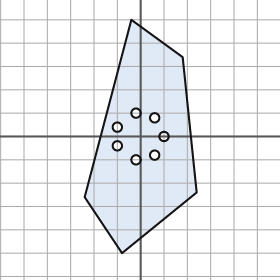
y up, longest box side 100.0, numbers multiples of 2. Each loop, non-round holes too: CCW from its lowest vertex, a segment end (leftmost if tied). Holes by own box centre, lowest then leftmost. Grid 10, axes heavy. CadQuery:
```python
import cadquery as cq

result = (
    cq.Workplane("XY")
    .moveTo(-8.0, -50.0)
    .lineTo(24.0, -24.0)
    .lineTo(18.0, 34.0)
    .lineTo(-4.0, 50.0)
    .lineTo(-24.0, -26.0)
    .close()
    .moveTo(-2.0, -10.0)
    .circle(2.0)
    .moveTo(6.0, -8.0)
    .circle(2.0)
    .moveTo(-10.0, -4.0)
    .circle(2.0)
    .moveTo(10.0, 0.0)
    .circle(2.0)
    .moveTo(-10.0, 4.0)
    .circle(2.0)
    .moveTo(6.0, 8.0)
    .circle(2.0)
    .moveTo(-2.0, 10.0)
    .circle(2.0)
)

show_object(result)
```